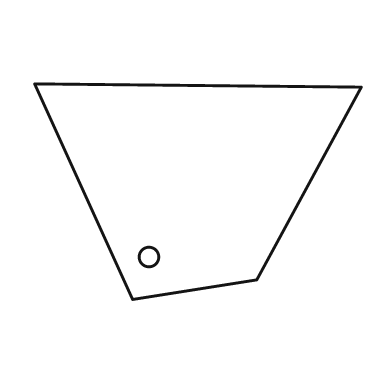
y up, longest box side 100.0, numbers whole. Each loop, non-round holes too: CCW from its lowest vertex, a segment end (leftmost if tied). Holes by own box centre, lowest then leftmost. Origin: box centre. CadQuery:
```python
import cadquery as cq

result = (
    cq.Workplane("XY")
    .moveTo(-20.0, -33.0)
    .lineTo(18.0, -27.0)
    .lineTo(50.0, 32.0)
    .lineTo(-50.0, 33.0)
    .close()
    .moveTo(-15.0, -20.0)
    .circle(3.0)
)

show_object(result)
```